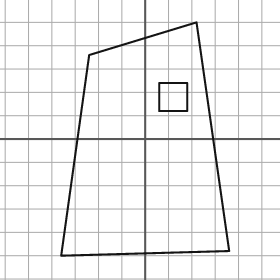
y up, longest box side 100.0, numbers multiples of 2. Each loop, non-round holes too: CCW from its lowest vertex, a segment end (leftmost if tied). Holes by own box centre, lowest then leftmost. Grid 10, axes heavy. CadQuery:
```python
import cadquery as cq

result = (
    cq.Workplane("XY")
    .moveTo(-36.0, -50.0)
    .lineTo(36.0, -48.0)
    .lineTo(22.0, 50.0)
    .lineTo(-24.0, 36.0)
    .close()
    .moveTo(6.0, 12.0)
    .lineTo(18.0, 12.0)
    .lineTo(18.0, 24.0)
    .lineTo(6.0, 24.0)
    .close()
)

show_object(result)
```